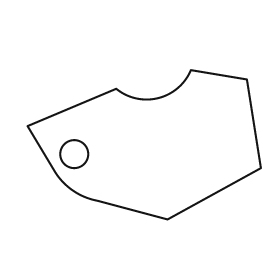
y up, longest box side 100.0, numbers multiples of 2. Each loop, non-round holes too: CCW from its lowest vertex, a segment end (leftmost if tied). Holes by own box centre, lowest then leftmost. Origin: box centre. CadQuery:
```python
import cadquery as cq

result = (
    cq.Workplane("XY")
    .moveTo(10.0, -32.0)
    .lineTo(50.0, -10.0)
    .lineTo(44.0, 28.0)
    .lineTo(20.0, 32.0)
    .threePointArc((6.0, 20.0), (-12.0, 24.0))
    .lineTo(-50.0, 8.0)
    .lineTo(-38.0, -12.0)
    .threePointArc((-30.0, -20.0), (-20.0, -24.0))
    .close()
    .moveTo(-30.0, -4.0)
    .circle(6.0)
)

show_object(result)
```